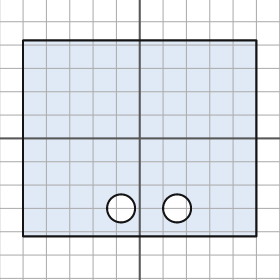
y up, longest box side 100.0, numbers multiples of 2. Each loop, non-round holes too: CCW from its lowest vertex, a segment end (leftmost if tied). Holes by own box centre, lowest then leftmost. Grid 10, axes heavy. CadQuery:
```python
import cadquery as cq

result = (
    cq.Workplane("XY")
    .moveTo(-50.0, -42.0)
    .lineTo(50.0, -42.0)
    .lineTo(50.0, 42.0)
    .lineTo(-50.0, 42.0)
    .close()
    .moveTo(-8.0, -30.0)
    .circle(6.0)
    .moveTo(16.0, -30.0)
    .circle(6.0)
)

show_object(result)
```